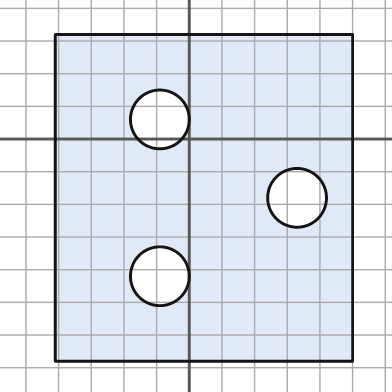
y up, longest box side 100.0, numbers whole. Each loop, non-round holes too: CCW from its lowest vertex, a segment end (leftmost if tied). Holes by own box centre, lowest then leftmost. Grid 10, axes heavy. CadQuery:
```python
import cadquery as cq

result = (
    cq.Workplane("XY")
    .moveTo(-41.0, -68.0)
    .lineTo(50.0, -68.0)
    .lineTo(50.0, 32.0)
    .lineTo(-41.0, 32.0)
    .close()
    .moveTo(-9.0, -42.0)
    .circle(9.0)
    .moveTo(33.0, -18.0)
    .circle(9.0)
    .moveTo(-9.0, 6.0)
    .circle(9.0)
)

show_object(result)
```